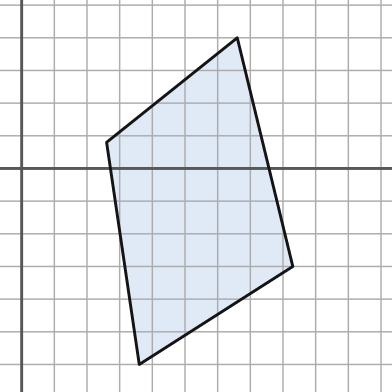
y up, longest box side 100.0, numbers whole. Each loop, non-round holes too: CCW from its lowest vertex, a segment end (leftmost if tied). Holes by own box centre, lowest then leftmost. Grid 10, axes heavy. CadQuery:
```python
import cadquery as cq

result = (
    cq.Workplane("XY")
    .moveTo(36.0, -60.0)
    .lineTo(83.0, -30.0)
    .lineTo(66.0, 40.0)
    .lineTo(26.0, 8.0)
    .close()
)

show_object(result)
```